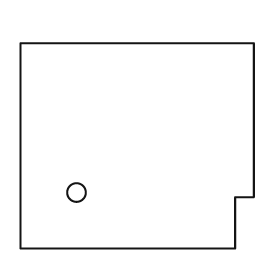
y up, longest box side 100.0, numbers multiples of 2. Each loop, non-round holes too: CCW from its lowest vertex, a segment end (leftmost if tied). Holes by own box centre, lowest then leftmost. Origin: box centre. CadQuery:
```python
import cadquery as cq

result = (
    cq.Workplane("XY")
    .moveTo(-50.0, -44.0)
    .lineTo(42.0, -44.0)
    .lineTo(42.0, -22.0)
    .lineTo(50.0, -22.0)
    .lineTo(50.0, 44.0)
    .lineTo(-50.0, 44.0)
    .close()
    .moveTo(-26.0, -20.0)
    .circle(4.0)
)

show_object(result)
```